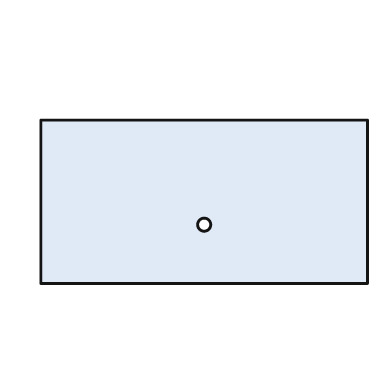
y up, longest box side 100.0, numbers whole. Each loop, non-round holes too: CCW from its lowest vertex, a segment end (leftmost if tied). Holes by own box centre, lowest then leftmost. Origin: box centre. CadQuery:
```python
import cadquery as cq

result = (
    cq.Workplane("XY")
    .moveTo(-50.0, -25.0)
    .lineTo(50.0, -25.0)
    .lineTo(50.0, 25.0)
    .lineTo(-50.0, 25.0)
    .close()
    .moveTo(0.0, -7.0)
    .circle(2.0)
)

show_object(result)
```